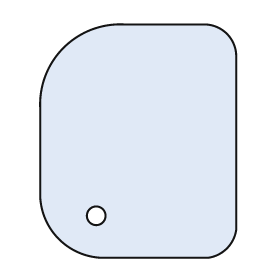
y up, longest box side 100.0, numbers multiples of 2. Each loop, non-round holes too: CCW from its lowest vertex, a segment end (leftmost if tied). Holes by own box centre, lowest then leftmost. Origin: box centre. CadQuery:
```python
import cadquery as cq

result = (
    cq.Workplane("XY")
    .moveTo(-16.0, -50.0)
    .lineTo(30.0, -50.0)
    .threePointArc((38.0, -46.0), (42.0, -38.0))
    .lineTo(42.0, 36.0)
    .threePointArc((38.0, 46.0), (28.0, 50.0))
    .lineTo(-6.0, 50.0)
    .threePointArc((-32.0, 40.0), (-42.0, 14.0))
    .lineTo(-42.0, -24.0)
    .threePointArc((-34.0, -42.0), (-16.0, -50.0))
    .close()
    .moveTo(-18.0, -32.0)
    .circle(4.0)
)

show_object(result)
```